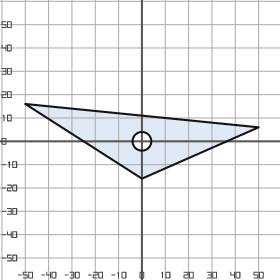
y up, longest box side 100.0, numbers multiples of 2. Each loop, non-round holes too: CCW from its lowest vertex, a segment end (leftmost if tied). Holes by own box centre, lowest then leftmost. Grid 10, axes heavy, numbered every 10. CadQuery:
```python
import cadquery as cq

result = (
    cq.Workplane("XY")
    .moveTo(0.0, -16.0)
    .lineTo(50.0, 6.0)
    .lineTo(-50.0, 16.0)
    .close()
    .moveTo(0.0, 0.0)
    .circle(4.0)
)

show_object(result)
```